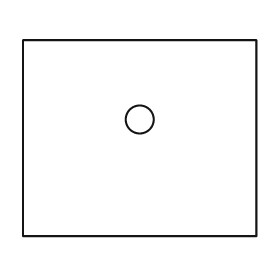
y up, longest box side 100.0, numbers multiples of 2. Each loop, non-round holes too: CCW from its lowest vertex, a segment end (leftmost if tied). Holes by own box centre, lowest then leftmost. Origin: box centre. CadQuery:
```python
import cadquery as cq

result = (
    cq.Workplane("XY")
    .moveTo(-50.0, -42.0)
    .lineTo(50.0, -42.0)
    .lineTo(50.0, 42.0)
    .lineTo(-50.0, 42.0)
    .close()
    .moveTo(0.0, 8.0)
    .circle(6.0)
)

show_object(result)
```